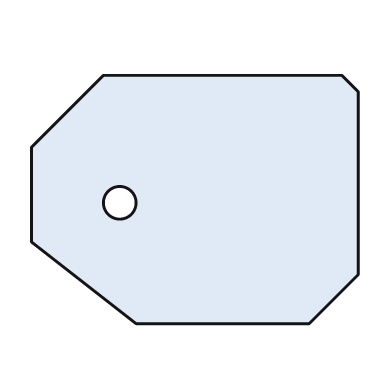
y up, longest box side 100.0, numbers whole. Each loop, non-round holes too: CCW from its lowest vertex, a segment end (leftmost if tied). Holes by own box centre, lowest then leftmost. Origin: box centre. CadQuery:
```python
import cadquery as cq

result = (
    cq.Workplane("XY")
    .moveTo(-18.0, -38.0)
    .lineTo(35.0, -38.0)
    .lineTo(50.0, -23.0)
    .lineTo(50.0, 33.0)
    .lineTo(45.0, 38.0)
    .lineTo(-28.0, 38.0)
    .lineTo(-50.0, 16.0)
    .lineTo(-50.0, -13.0)
    .close()
    .moveTo(-23.0, -1.0)
    .circle(5.0)
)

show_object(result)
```